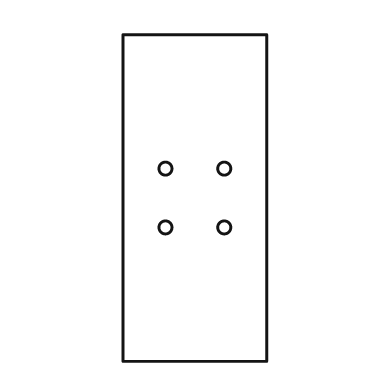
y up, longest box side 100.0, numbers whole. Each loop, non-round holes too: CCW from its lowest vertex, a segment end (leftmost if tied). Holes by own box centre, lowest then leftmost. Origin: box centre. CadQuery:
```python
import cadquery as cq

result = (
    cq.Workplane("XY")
    .moveTo(-22.0, -50.0)
    .lineTo(22.0, -50.0)
    .lineTo(22.0, 50.0)
    .lineTo(-22.0, 50.0)
    .close()
    .moveTo(-9.0, -9.0)
    .circle(2.0)
    .moveTo(9.0, -9.0)
    .circle(2.0)
    .moveTo(-9.0, 9.0)
    .circle(2.0)
    .moveTo(9.0, 9.0)
    .circle(2.0)
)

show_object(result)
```